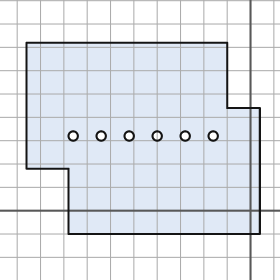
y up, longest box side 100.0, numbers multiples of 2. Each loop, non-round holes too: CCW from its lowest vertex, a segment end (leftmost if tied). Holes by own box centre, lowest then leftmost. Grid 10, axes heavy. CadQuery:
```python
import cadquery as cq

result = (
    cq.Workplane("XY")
    .moveTo(-78.0, -10.0)
    .lineTo(4.0, -10.0)
    .lineTo(4.0, 44.0)
    .lineTo(-10.0, 44.0)
    .lineTo(-10.0, 72.0)
    .lineTo(-96.0, 72.0)
    .lineTo(-96.0, 18.0)
    .lineTo(-78.0, 18.0)
    .close()
    .moveTo(-76.0, 32.0)
    .circle(2.0)
    .moveTo(-64.0, 32.0)
    .circle(2.0)
    .moveTo(-52.0, 32.0)
    .circle(2.0)
    .moveTo(-40.0, 32.0)
    .circle(2.0)
    .moveTo(-28.0, 32.0)
    .circle(2.0)
    .moveTo(-16.0, 32.0)
    .circle(2.0)
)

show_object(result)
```